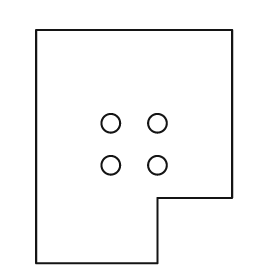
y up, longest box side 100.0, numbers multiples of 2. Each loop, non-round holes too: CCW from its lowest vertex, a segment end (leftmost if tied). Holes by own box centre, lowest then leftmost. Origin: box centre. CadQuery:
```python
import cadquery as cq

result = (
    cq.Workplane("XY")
    .moveTo(-42.0, -50.0)
    .lineTo(10.0, -50.0)
    .lineTo(10.0, -22.0)
    .lineTo(42.0, -22.0)
    .lineTo(42.0, 50.0)
    .lineTo(-42.0, 50.0)
    .close()
    .moveTo(-10.0, -8.0)
    .circle(4.0)
    .moveTo(10.0, -8.0)
    .circle(4.0)
    .moveTo(-10.0, 10.0)
    .circle(4.0)
    .moveTo(10.0, 10.0)
    .circle(4.0)
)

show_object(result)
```